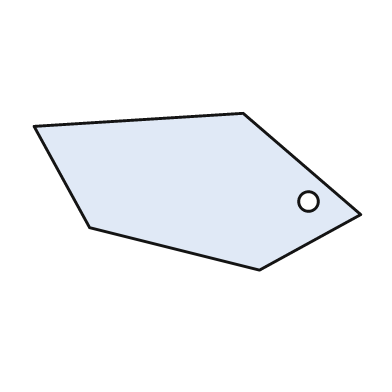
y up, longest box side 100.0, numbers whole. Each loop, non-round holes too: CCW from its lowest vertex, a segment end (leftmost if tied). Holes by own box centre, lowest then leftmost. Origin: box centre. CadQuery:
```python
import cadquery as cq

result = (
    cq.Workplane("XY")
    .moveTo(19.0, -24.0)
    .lineTo(50.0, -7.0)
    .lineTo(14.0, 24.0)
    .lineTo(-50.0, 20.0)
    .lineTo(-33.0, -11.0)
    .close()
    .moveTo(34.0, -3.0)
    .circle(3.0)
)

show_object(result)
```